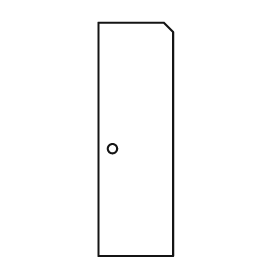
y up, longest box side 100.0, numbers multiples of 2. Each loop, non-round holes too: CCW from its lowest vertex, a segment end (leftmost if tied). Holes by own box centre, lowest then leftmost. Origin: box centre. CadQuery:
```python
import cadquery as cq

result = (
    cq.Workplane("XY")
    .moveTo(-16.0, -50.0)
    .lineTo(16.0, -50.0)
    .lineTo(16.0, 46.0)
    .lineTo(12.0, 50.0)
    .lineTo(-16.0, 50.0)
    .close()
    .moveTo(-10.0, -4.0)
    .circle(2.0)
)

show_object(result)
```